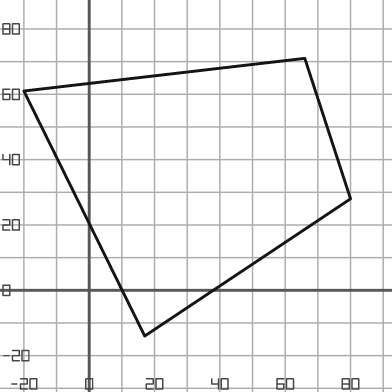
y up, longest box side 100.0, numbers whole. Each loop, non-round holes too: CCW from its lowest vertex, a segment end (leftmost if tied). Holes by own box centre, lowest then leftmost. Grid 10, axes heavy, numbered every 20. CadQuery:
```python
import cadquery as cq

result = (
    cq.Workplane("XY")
    .moveTo(17.0, -14.0)
    .lineTo(80.0, 28.0)
    .lineTo(66.0, 71.0)
    .lineTo(-20.0, 61.0)
    .close()
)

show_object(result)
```